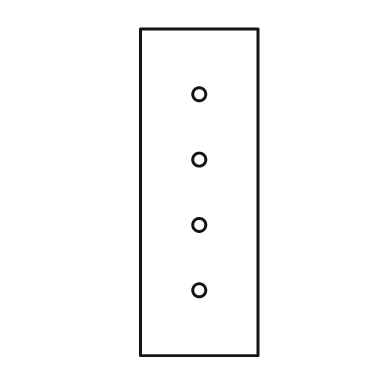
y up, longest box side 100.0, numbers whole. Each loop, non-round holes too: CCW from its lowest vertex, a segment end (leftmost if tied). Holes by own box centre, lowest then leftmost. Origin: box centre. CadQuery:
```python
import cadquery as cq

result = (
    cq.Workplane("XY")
    .moveTo(-18.0, -50.0)
    .lineTo(18.0, -50.0)
    .lineTo(18.0, 50.0)
    .lineTo(-18.0, 50.0)
    .close()
    .moveTo(0.0, -30.0)
    .circle(2.0)
    .moveTo(0.0, -10.0)
    .circle(2.0)
    .moveTo(0.0, 10.0)
    .circle(2.0)
    .moveTo(0.0, 30.0)
    .circle(2.0)
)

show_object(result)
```